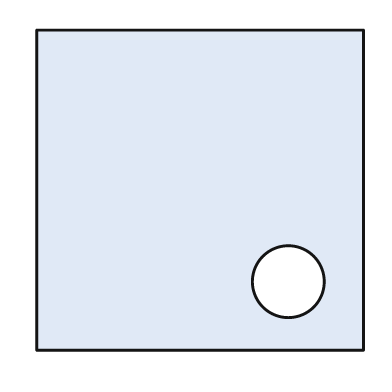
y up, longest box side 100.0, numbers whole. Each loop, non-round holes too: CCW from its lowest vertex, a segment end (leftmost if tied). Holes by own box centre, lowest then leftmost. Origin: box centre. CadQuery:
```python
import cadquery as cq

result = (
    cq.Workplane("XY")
    .moveTo(-50.0, -49.0)
    .lineTo(50.0, -49.0)
    .lineTo(50.0, 49.0)
    .lineTo(-50.0, 49.0)
    .close()
    .moveTo(27.0, -28.0)
    .circle(11.0)
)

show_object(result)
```